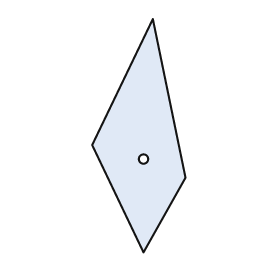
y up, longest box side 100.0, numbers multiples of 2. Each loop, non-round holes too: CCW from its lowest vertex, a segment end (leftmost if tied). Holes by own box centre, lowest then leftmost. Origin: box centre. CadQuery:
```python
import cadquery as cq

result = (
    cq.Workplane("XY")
    .moveTo(2.0, -50.0)
    .lineTo(20.0, -18.0)
    .lineTo(6.0, 50.0)
    .lineTo(-20.0, -4.0)
    .close()
    .moveTo(2.0, -10.0)
    .circle(2.0)
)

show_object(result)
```